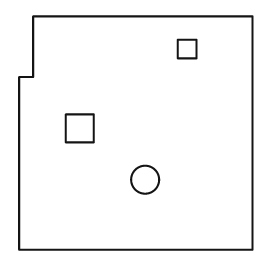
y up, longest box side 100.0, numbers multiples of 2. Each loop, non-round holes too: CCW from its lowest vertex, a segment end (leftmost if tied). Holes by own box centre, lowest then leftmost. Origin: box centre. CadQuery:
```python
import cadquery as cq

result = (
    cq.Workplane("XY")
    .moveTo(-50.0, -50.0)
    .lineTo(50.0, -50.0)
    .lineTo(50.0, 50.0)
    .lineTo(-44.0, 50.0)
    .lineTo(-44.0, 24.0)
    .lineTo(-50.0, 24.0)
    .close()
    .moveTo(4.0, -20.0)
    .circle(6.0)
    .moveTo(-30.0, -4.0)
    .lineTo(-18.0, -4.0)
    .lineTo(-18.0, 8.0)
    .lineTo(-30.0, 8.0)
    .close()
    .moveTo(18.0, 32.0)
    .lineTo(26.0, 32.0)
    .lineTo(26.0, 40.0)
    .lineTo(18.0, 40.0)
    .close()
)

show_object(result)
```